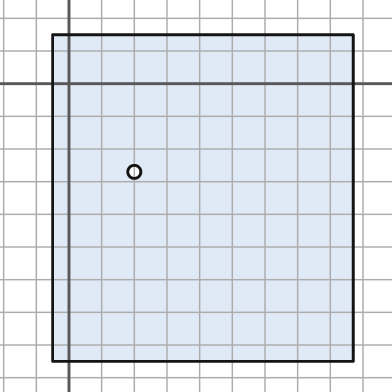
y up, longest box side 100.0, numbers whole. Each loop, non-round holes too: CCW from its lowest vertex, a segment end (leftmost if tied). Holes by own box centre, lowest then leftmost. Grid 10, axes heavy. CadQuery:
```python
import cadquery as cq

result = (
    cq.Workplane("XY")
    .moveTo(-5.0, -85.0)
    .lineTo(87.0, -85.0)
    .lineTo(87.0, 15.0)
    .lineTo(-5.0, 15.0)
    .close()
    .moveTo(20.0, -27.0)
    .circle(2.0)
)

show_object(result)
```